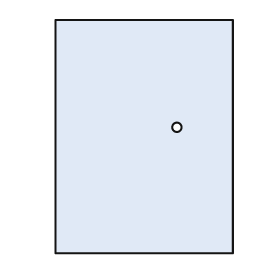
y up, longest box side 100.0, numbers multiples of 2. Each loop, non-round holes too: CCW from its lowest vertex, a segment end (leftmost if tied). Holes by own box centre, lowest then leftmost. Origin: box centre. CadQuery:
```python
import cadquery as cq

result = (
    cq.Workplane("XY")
    .moveTo(-38.0, -50.0)
    .lineTo(38.0, -50.0)
    .lineTo(38.0, 50.0)
    .lineTo(-38.0, 50.0)
    .close()
    .moveTo(14.0, 4.0)
    .circle(2.0)
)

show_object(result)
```